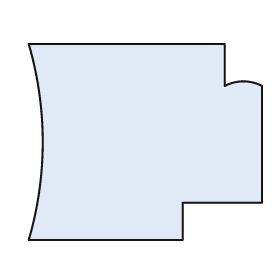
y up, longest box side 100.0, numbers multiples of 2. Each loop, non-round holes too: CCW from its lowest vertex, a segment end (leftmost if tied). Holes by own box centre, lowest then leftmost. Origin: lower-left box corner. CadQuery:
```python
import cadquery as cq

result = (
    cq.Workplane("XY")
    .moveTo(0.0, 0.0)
    .lineTo(66.0, 0.0)
    .lineTo(66.0, 16.0)
    .lineTo(100.0, 16.0)
    .lineTo(100.0, 66.0)
    .threePointArc((92.0, 68.0), (84.0, 66.0))
    .lineTo(84.0, 84.0)
    .lineTo(0.0, 84.0)
    .threePointArc((6.0, 42.0), (0.0, 0.0))
    .close()
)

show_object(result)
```